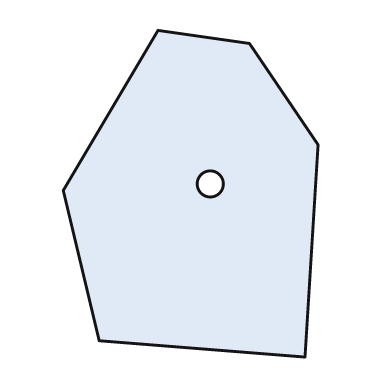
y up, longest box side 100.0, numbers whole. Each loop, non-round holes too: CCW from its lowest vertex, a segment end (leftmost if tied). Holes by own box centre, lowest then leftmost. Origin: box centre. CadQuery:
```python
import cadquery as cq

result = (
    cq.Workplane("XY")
    .moveTo(35.0, -50.0)
    .lineTo(39.0, 15.0)
    .lineTo(18.0, 46.0)
    .lineTo(-10.0, 50.0)
    .lineTo(-39.0, 1.0)
    .lineTo(-28.0, -45.0)
    .close()
    .moveTo(6.0, 3.0)
    .circle(4.0)
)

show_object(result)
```